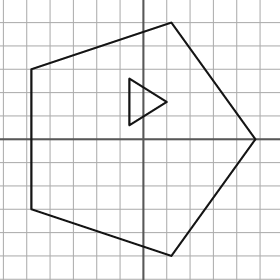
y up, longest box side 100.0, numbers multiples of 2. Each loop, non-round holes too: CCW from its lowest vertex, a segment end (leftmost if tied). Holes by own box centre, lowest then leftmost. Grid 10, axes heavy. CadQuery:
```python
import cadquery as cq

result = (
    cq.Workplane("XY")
    .moveTo(12.0, -50.0)
    .lineTo(48.0, 0.0)
    .lineTo(12.0, 50.0)
    .lineTo(-48.0, 30.0)
    .lineTo(-48.0, -30.0)
    .close()
    .moveTo(-6.0, 6.0)
    .lineTo(10.0, 16.0)
    .lineTo(-6.0, 26.0)
    .close()
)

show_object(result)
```